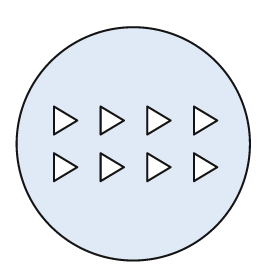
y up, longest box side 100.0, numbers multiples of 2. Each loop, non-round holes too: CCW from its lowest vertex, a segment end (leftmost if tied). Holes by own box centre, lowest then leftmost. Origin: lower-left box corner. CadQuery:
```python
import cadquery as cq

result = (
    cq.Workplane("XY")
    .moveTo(50.0, 50.0)
    .circle(50.0)
    .moveTo(16.0, 34.0)
    .lineTo(26.0, 40.0)
    .lineTo(16.0, 46.0)
    .close()
    .moveTo(36.0, 34.0)
    .lineTo(46.0, 40.0)
    .lineTo(36.0, 46.0)
    .close()
    .moveTo(56.0, 34.0)
    .lineTo(66.0, 40.0)
    .lineTo(56.0, 46.0)
    .close()
    .moveTo(76.0, 34.0)
    .lineTo(86.0, 40.0)
    .lineTo(76.0, 46.0)
    .close()
    .moveTo(16.0, 54.0)
    .lineTo(26.0, 60.0)
    .lineTo(16.0, 66.0)
    .close()
    .moveTo(36.0, 54.0)
    .lineTo(46.0, 60.0)
    .lineTo(36.0, 66.0)
    .close()
    .moveTo(56.0, 54.0)
    .lineTo(66.0, 60.0)
    .lineTo(56.0, 66.0)
    .close()
    .moveTo(76.0, 54.0)
    .lineTo(86.0, 60.0)
    .lineTo(76.0, 66.0)
    .close()
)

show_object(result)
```